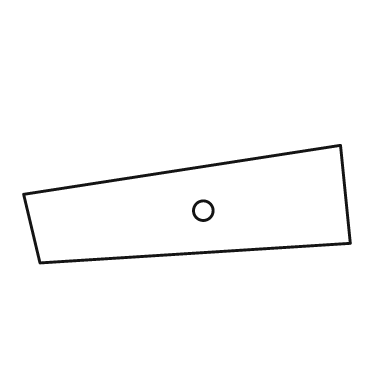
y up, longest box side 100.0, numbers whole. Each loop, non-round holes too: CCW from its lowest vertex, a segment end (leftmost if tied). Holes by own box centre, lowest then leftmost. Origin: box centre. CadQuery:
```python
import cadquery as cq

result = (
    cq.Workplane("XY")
    .moveTo(-45.0, -18.0)
    .lineTo(50.0, -12.0)
    .lineTo(47.0, 18.0)
    .lineTo(-50.0, 3.0)
    .close()
    .moveTo(5.0, -2.0)
    .circle(3.0)
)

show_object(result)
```